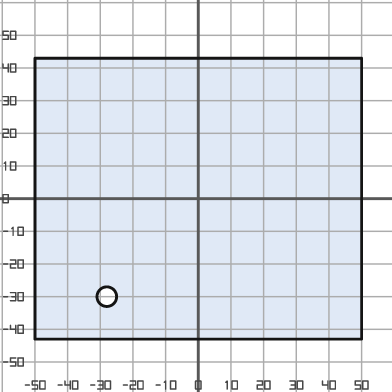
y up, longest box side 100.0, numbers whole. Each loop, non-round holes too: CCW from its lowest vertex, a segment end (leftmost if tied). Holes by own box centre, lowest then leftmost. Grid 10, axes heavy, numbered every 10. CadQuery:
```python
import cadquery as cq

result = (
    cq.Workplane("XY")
    .moveTo(-50.0, -43.0)
    .lineTo(50.0, -43.0)
    .lineTo(50.0, 43.0)
    .lineTo(-50.0, 43.0)
    .close()
    .moveTo(-28.0, -30.0)
    .circle(3.0)
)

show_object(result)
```